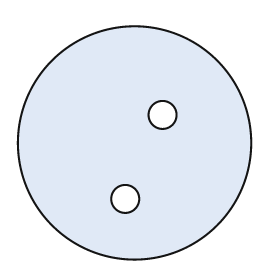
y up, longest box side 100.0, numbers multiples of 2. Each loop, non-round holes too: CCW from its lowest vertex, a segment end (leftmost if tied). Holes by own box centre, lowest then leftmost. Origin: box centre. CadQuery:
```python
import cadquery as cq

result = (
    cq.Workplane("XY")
    .moveTo(0.0, 0.0)
    .circle(50.0)
    .moveTo(-4.0, -24.0)
    .circle(6.0)
    .moveTo(12.0, 12.0)
    .circle(6.0)
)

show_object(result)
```